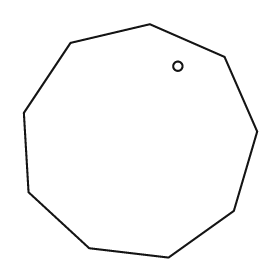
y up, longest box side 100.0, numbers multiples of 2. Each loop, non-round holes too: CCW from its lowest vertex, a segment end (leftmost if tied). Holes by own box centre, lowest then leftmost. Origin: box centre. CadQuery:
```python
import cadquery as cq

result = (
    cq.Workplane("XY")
    .moveTo(12.0, -50.0)
    .lineTo(40.0, -30.0)
    .lineTo(50.0, 4.0)
    .lineTo(36.0, 36.0)
    .lineTo(4.0, 50.0)
    .lineTo(-30.0, 42.0)
    .lineTo(-50.0, 12.0)
    .lineTo(-48.0, -22.0)
    .lineTo(-22.0, -46.0)
    .close()
    .moveTo(16.0, 32.0)
    .circle(2.0)
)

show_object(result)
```